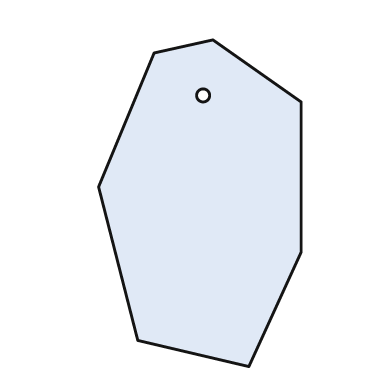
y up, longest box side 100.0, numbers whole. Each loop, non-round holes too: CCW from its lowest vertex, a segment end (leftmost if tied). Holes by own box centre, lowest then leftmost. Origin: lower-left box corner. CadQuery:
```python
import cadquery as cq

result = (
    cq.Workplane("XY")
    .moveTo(46.0, 0.0)
    .lineTo(62.0, 35.0)
    .lineTo(62.0, 81.0)
    .lineTo(35.0, 100.0)
    .lineTo(17.0, 96.0)
    .lineTo(0.0, 55.0)
    .lineTo(12.0, 8.0)
    .close()
    .moveTo(32.0, 83.0)
    .circle(2.0)
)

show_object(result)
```